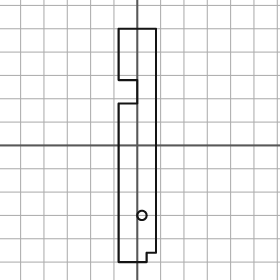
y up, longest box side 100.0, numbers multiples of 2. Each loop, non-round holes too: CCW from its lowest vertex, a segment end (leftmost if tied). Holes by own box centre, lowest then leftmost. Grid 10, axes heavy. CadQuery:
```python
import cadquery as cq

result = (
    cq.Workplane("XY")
    .moveTo(-8.0, -50.0)
    .lineTo(4.0, -50.0)
    .lineTo(4.0, -46.0)
    .lineTo(8.0, -46.0)
    .lineTo(8.0, 50.0)
    .lineTo(-8.0, 50.0)
    .lineTo(-8.0, 28.0)
    .lineTo(0.0, 28.0)
    .lineTo(0.0, 18.0)
    .lineTo(-8.0, 18.0)
    .close()
    .moveTo(2.0, -30.0)
    .circle(2.0)
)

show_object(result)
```